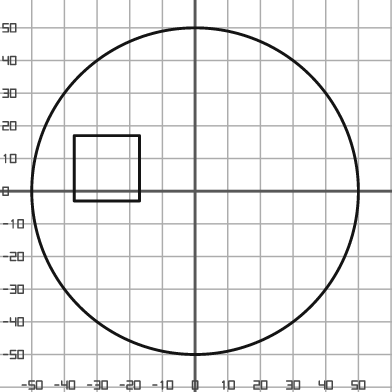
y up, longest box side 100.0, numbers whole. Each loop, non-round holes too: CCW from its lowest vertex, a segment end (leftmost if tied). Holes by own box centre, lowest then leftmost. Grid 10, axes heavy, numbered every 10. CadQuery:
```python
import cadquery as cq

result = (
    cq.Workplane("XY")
    .moveTo(0.0, 0.0)
    .circle(50.0)
    .moveTo(-37.0, -3.0)
    .lineTo(-17.0, -3.0)
    .lineTo(-17.0, 17.0)
    .lineTo(-37.0, 17.0)
    .close()
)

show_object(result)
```